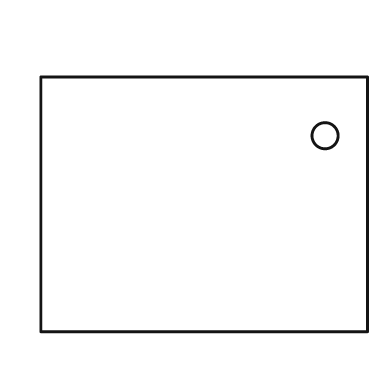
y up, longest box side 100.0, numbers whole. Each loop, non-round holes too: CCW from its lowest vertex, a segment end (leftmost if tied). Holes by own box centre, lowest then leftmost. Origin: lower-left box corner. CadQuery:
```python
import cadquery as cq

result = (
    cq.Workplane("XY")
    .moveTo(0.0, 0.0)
    .lineTo(100.0, 0.0)
    .lineTo(100.0, 78.0)
    .lineTo(0.0, 78.0)
    .close()
    .moveTo(87.0, 60.0)
    .circle(4.0)
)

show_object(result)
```